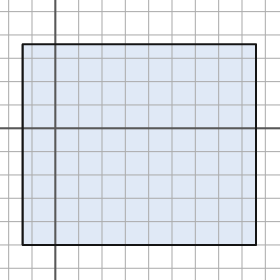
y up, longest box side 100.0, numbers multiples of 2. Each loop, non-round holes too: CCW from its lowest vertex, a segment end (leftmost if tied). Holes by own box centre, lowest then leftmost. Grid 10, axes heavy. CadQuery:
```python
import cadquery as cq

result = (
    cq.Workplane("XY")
    .moveTo(-14.0, -50.0)
    .lineTo(86.0, -50.0)
    .lineTo(86.0, 36.0)
    .lineTo(-14.0, 36.0)
    .close()
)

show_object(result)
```